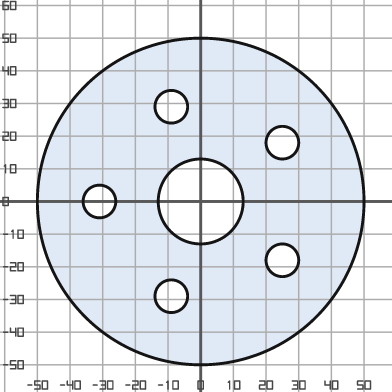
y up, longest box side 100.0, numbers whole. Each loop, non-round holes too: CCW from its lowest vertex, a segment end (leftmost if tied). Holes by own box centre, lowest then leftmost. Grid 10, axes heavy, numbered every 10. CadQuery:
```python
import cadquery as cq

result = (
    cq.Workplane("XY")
    .moveTo(0.0, 0.0)
    .circle(50.0)
    .moveTo(-9.0, -29.0)
    .circle(5.0)
    .moveTo(25.0, -18.0)
    .circle(5.0)
    .moveTo(-31.0, 0.0)
    .circle(5.0)
    .moveTo(0.0, 0.0)
    .circle(13.0)
    .moveTo(25.0, 18.0)
    .circle(5.0)
    .moveTo(-9.0, 29.0)
    .circle(5.0)
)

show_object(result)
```